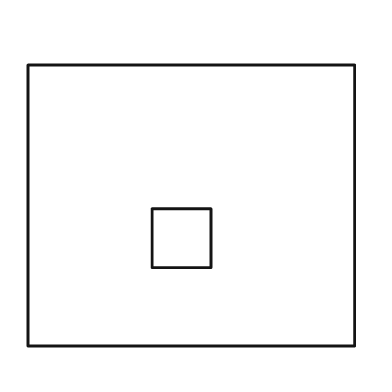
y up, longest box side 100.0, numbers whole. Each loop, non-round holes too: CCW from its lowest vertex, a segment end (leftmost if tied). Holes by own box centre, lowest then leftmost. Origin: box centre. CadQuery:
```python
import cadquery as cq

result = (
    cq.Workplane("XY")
    .moveTo(-50.0, -43.0)
    .lineTo(50.0, -43.0)
    .lineTo(50.0, 43.0)
    .lineTo(-50.0, 43.0)
    .close()
    .moveTo(-12.0, -19.0)
    .lineTo(6.0, -19.0)
    .lineTo(6.0, -1.0)
    .lineTo(-12.0, -1.0)
    .close()
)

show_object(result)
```